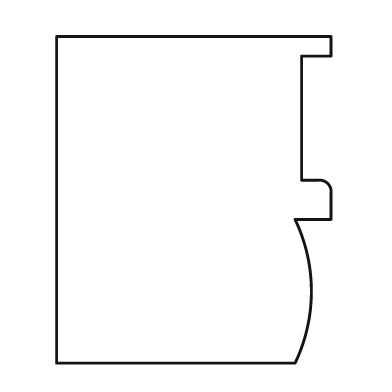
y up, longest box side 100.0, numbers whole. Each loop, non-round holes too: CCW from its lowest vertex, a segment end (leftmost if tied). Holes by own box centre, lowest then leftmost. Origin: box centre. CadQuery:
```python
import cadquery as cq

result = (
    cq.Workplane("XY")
    .moveTo(-42.0, -50.0)
    .lineTo(31.0, -50.0)
    .threePointArc((36.0, -28.0), (31.0, -6.0))
    .lineTo(42.0, -6.0)
    .lineTo(42.0, 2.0)
    .threePointArc((41.0, 5.0), (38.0, 6.0))
    .lineTo(33.0, 6.0)
    .lineTo(33.0, 44.0)
    .lineTo(42.0, 44.0)
    .lineTo(42.0, 50.0)
    .lineTo(-42.0, 50.0)
    .close()
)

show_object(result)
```